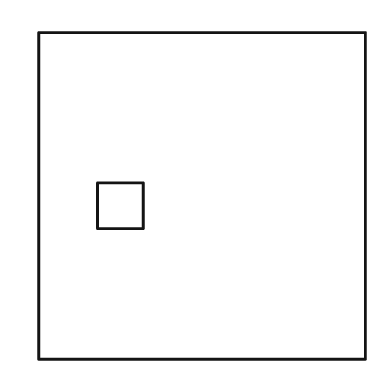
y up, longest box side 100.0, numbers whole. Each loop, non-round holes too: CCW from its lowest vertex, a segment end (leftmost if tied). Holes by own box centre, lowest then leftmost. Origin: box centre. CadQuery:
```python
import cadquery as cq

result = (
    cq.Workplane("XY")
    .moveTo(-50.0, -50.0)
    .lineTo(50.0, -50.0)
    .lineTo(50.0, 50.0)
    .lineTo(-50.0, 50.0)
    .close()
    .moveTo(-32.0, -10.0)
    .lineTo(-18.0, -10.0)
    .lineTo(-18.0, 4.0)
    .lineTo(-32.0, 4.0)
    .close()
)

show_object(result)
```